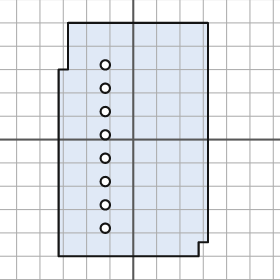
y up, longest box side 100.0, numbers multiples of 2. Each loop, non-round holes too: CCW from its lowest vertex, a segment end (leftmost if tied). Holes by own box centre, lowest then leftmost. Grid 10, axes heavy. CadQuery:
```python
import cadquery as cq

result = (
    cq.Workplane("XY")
    .moveTo(-32.0, -50.0)
    .lineTo(28.0, -50.0)
    .lineTo(28.0, -44.0)
    .lineTo(32.0, -44.0)
    .lineTo(32.0, 50.0)
    .lineTo(-28.0, 50.0)
    .lineTo(-28.0, 30.0)
    .lineTo(-32.0, 30.0)
    .close()
    .moveTo(-12.0, -38.0)
    .circle(2.0)
    .moveTo(-12.0, -28.0)
    .circle(2.0)
    .moveTo(-12.0, -18.0)
    .circle(2.0)
    .moveTo(-12.0, -8.0)
    .circle(2.0)
    .moveTo(-12.0, 2.0)
    .circle(2.0)
    .moveTo(-12.0, 12.0)
    .circle(2.0)
    .moveTo(-12.0, 22.0)
    .circle(2.0)
    .moveTo(-12.0, 32.0)
    .circle(2.0)
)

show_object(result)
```